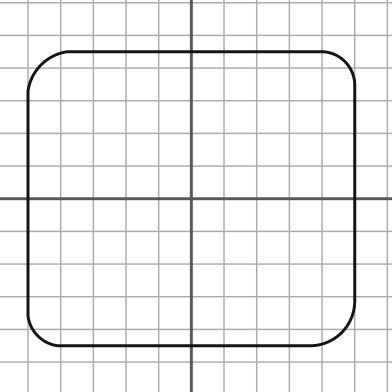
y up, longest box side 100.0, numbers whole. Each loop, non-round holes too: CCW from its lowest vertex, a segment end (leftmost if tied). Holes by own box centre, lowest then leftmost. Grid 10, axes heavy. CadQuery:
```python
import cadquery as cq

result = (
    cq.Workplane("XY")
    .moveTo(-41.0, -45.0)
    .lineTo(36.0, -45.0)
    .threePointArc((46.0, -41.0), (50.0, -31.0))
    .lineTo(50.0, 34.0)
    .threePointArc((47.0, 42.0), (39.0, 45.0))
    .lineTo(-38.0, 45.0)
    .threePointArc((-46.0, 41.0), (-50.0, 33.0))
    .lineTo(-50.0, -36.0)
    .threePointArc((-47.0, -42.0), (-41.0, -45.0))
    .close()
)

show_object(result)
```